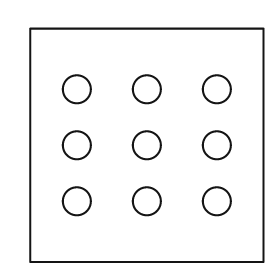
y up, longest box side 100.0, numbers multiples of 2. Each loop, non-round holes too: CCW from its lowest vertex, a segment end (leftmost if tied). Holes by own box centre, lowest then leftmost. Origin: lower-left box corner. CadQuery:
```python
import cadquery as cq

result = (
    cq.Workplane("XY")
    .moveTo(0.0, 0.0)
    .lineTo(100.0, 0.0)
    .lineTo(100.0, 100.0)
    .lineTo(0.0, 100.0)
    .close()
    .moveTo(20.0, 26.0)
    .circle(6.0)
    .moveTo(50.0, 26.0)
    .circle(6.0)
    .moveTo(80.0, 26.0)
    .circle(6.0)
    .moveTo(20.0, 50.0)
    .circle(6.0)
    .moveTo(50.0, 50.0)
    .circle(6.0)
    .moveTo(80.0, 50.0)
    .circle(6.0)
    .moveTo(20.0, 74.0)
    .circle(6.0)
    .moveTo(50.0, 74.0)
    .circle(6.0)
    .moveTo(80.0, 74.0)
    .circle(6.0)
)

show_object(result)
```